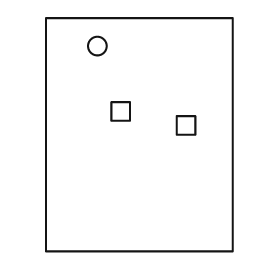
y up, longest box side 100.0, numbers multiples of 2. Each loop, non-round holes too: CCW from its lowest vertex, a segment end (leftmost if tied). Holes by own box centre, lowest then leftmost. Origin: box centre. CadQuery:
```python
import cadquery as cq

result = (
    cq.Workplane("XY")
    .moveTo(-40.0, -50.0)
    .lineTo(40.0, -50.0)
    .lineTo(40.0, 50.0)
    .lineTo(-40.0, 50.0)
    .close()
    .moveTo(16.0, 0.0)
    .lineTo(24.0, 0.0)
    .lineTo(24.0, 8.0)
    .lineTo(16.0, 8.0)
    .close()
    .moveTo(-12.0, 6.0)
    .lineTo(-4.0, 6.0)
    .lineTo(-4.0, 14.0)
    .lineTo(-12.0, 14.0)
    .close()
    .moveTo(-18.0, 38.0)
    .circle(4.0)
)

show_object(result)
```